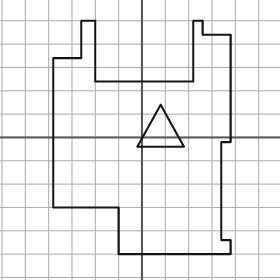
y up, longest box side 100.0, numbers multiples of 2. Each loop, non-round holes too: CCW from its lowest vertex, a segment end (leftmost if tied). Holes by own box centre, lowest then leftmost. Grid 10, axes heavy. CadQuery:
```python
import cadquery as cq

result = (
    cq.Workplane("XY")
    .moveTo(-10.0, -50.0)
    .lineTo(38.0, -50.0)
    .lineTo(38.0, -44.0)
    .lineTo(34.0, -44.0)
    .lineTo(34.0, -2.0)
    .lineTo(38.0, -2.0)
    .lineTo(38.0, 44.0)
    .lineTo(26.0, 44.0)
    .lineTo(26.0, 50.0)
    .lineTo(22.0, 50.0)
    .lineTo(22.0, 24.0)
    .lineTo(-20.0, 24.0)
    .lineTo(-20.0, 50.0)
    .lineTo(-26.0, 50.0)
    .lineTo(-26.0, 34.0)
    .lineTo(-38.0, 34.0)
    .lineTo(-38.0, -30.0)
    .lineTo(-10.0, -30.0)
    .close()
    .moveTo(-2.0, -4.0)
    .lineTo(18.0, -4.0)
    .lineTo(8.0, 14.0)
    .close()
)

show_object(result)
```